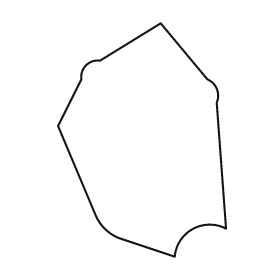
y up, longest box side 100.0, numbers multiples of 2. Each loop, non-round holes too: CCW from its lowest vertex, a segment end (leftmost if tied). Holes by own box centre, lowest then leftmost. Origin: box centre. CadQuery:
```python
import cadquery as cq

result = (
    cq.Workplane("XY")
    .moveTo(14.0, -50.0)
    .threePointArc((22.0, -38.0), (36.0, -38.0))
    .lineTo(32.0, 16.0)
    .threePointArc((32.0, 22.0), (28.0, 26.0))
    .lineTo(8.0, 50.0)
    .lineTo(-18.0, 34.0)
    .threePointArc((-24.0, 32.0), (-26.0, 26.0))
    .lineTo(-36.0, 6.0)
    .lineTo(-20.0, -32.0)
    .threePointArc((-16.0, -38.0), (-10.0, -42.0))
    .close()
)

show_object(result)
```